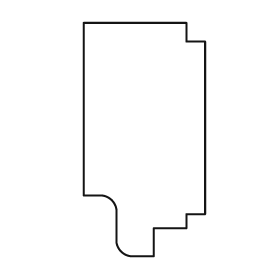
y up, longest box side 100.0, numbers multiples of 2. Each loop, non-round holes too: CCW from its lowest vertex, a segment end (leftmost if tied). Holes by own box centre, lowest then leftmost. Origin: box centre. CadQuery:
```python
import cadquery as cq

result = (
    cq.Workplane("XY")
    .moveTo(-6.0, -50.0)
    .lineTo(4.0, -50.0)
    .lineTo(4.0, -38.0)
    .lineTo(18.0, -38.0)
    .lineTo(18.0, -32.0)
    .lineTo(26.0, -32.0)
    .lineTo(26.0, 42.0)
    .lineTo(18.0, 42.0)
    .lineTo(18.0, 50.0)
    .lineTo(-26.0, 50.0)
    .lineTo(-26.0, -24.0)
    .lineTo(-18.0, -24.0)
    .threePointArc((-14.0, -26.0), (-12.0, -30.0))
    .lineTo(-12.0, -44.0)
    .threePointArc((-10.0, -48.0), (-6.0, -50.0))
    .close()
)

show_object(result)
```